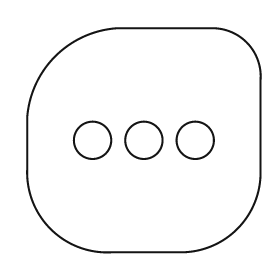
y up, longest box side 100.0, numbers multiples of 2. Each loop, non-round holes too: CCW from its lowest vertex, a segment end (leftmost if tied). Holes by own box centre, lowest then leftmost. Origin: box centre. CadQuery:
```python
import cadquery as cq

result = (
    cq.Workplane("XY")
    .moveTo(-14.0, -48.0)
    .lineTo(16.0, -48.0)
    .threePointArc((40.0, -38.0), (50.0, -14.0))
    .lineTo(50.0, 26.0)
    .threePointArc((44.0, 42.0), (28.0, 48.0))
    .lineTo(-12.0, 48.0)
    .threePointArc((-38.0, 36.0), (-50.0, 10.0))
    .lineTo(-50.0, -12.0)
    .threePointArc((-40.0, -38.0), (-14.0, -48.0))
    .close()
    .moveTo(-22.0, 0.0)
    .circle(8.0)
    .moveTo(0.0, 0.0)
    .circle(8.0)
    .moveTo(22.0, 0.0)
    .circle(8.0)
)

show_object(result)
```